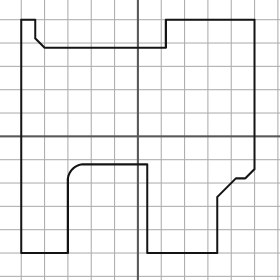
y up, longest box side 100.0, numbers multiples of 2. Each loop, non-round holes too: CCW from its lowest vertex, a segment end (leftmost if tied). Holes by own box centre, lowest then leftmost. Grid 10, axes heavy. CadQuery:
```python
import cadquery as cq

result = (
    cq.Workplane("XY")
    .moveTo(-50.0, -50.0)
    .lineTo(-30.0, -50.0)
    .lineTo(-30.0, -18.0)
    .threePointArc((-28.0, -14.0), (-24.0, -12.0))
    .lineTo(4.0, -12.0)
    .lineTo(4.0, -50.0)
    .lineTo(34.0, -50.0)
    .lineTo(34.0, -26.0)
    .lineTo(42.0, -18.0)
    .lineTo(46.0, -18.0)
    .lineTo(50.0, -14.0)
    .lineTo(50.0, 50.0)
    .lineTo(12.0, 50.0)
    .lineTo(12.0, 38.0)
    .lineTo(-40.0, 38.0)
    .lineTo(-44.0, 42.0)
    .lineTo(-44.0, 50.0)
    .lineTo(-50.0, 50.0)
    .close()
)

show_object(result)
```